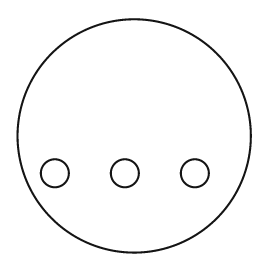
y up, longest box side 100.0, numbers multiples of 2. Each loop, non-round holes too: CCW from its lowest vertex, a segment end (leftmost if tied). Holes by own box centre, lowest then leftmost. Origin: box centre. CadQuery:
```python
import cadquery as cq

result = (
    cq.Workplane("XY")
    .moveTo(0.0, 0.0)
    .circle(50.0)
    .moveTo(-34.0, -16.0)
    .circle(6.0)
    .moveTo(-4.0, -16.0)
    .circle(6.0)
    .moveTo(26.0, -16.0)
    .circle(6.0)
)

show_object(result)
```